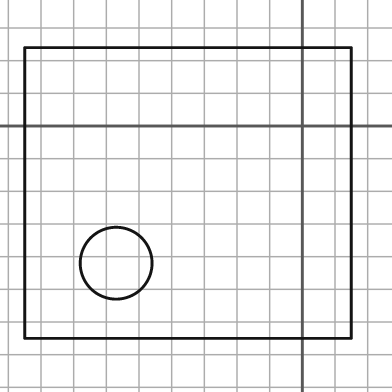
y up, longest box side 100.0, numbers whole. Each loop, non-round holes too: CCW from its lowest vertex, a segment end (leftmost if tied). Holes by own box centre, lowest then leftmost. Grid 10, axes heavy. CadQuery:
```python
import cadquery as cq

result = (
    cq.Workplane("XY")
    .moveTo(-85.0, -65.0)
    .lineTo(15.0, -65.0)
    .lineTo(15.0, 24.0)
    .lineTo(-85.0, 24.0)
    .close()
    .moveTo(-57.0, -42.0)
    .circle(11.0)
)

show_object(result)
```